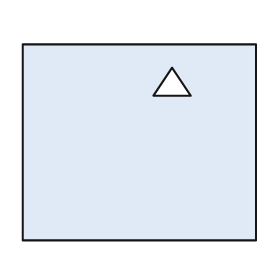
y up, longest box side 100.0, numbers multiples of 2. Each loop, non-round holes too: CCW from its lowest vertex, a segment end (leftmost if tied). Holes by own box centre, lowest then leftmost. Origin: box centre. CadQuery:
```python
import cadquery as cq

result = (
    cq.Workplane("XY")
    .moveTo(-50.0, -42.0)
    .lineTo(50.0, -42.0)
    .lineTo(50.0, 42.0)
    .lineTo(-50.0, 42.0)
    .close()
    .moveTo(6.0, 20.0)
    .lineTo(22.0, 20.0)
    .lineTo(14.0, 32.0)
    .close()
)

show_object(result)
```